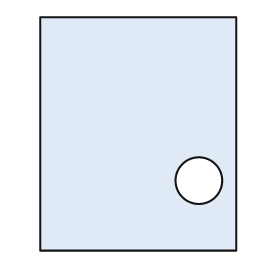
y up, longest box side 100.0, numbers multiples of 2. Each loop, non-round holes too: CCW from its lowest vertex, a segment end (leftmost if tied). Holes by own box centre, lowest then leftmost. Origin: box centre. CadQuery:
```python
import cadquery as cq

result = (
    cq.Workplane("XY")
    .moveTo(-42.0, -50.0)
    .lineTo(42.0, -50.0)
    .lineTo(42.0, 50.0)
    .lineTo(-42.0, 50.0)
    .close()
    .moveTo(26.0, -20.0)
    .circle(10.0)
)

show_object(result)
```